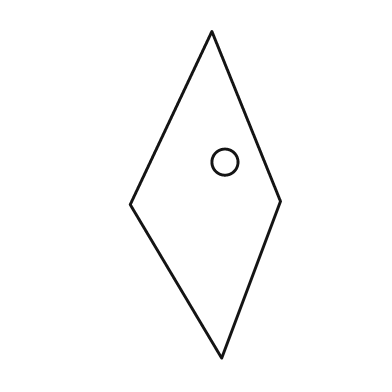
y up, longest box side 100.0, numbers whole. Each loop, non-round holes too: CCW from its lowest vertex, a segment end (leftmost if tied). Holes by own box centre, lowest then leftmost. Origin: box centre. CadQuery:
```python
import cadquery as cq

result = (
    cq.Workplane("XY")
    .moveTo(5.0, -50.0)
    .lineTo(23.0, -2.0)
    .lineTo(2.0, 50.0)
    .lineTo(-23.0, -3.0)
    .close()
    .moveTo(6.0, 10.0)
    .circle(4.0)
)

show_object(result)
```